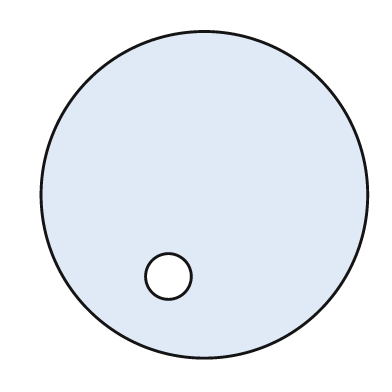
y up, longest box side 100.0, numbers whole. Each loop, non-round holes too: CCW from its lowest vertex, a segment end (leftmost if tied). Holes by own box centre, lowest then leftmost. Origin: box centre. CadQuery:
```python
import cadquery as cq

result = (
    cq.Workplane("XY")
    .moveTo(0.0, 0.0)
    .circle(50.0)
    .moveTo(-11.0, -25.0)
    .circle(7.0)
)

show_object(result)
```